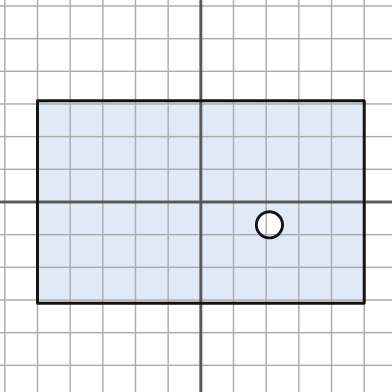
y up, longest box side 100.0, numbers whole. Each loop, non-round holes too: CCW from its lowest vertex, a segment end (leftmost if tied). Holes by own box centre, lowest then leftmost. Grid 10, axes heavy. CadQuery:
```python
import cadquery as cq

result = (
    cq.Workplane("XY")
    .moveTo(-50.0, -31.0)
    .lineTo(50.0, -31.0)
    .lineTo(50.0, 31.0)
    .lineTo(-50.0, 31.0)
    .close()
    .moveTo(21.0, -7.0)
    .circle(4.0)
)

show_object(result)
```